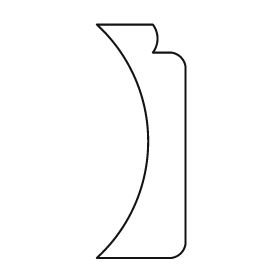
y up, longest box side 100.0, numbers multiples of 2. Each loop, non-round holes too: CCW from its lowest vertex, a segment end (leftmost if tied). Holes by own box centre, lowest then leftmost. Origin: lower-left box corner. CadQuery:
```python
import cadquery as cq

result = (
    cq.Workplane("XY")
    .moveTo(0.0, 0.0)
    .lineTo(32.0, 0.0)
    .threePointArc((36.0, 2.0), (38.0, 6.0))
    .lineTo(38.0, 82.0)
    .threePointArc((36.0, 86.0), (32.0, 88.0))
    .lineTo(24.0, 88.0)
    .threePointArc((26.0, 94.0), (24.0, 100.0))
    .lineTo(0.0, 100.0)
    .threePointArc((22.0, 50.0), (0.0, 0.0))
    .close()
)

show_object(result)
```